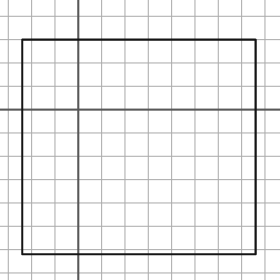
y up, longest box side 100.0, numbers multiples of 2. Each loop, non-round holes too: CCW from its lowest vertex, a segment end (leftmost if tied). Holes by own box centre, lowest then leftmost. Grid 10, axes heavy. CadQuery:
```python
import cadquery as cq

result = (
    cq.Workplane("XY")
    .moveTo(-24.0, -62.0)
    .lineTo(76.0, -62.0)
    .lineTo(76.0, 30.0)
    .lineTo(-24.0, 30.0)
    .close()
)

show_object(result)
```